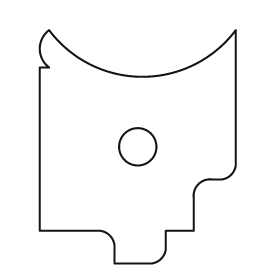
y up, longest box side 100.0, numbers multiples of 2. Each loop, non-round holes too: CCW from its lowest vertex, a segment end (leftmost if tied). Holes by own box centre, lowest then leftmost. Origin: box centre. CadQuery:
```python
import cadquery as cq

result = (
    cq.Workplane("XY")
    .moveTo(-10.0, -50.0)
    .lineTo(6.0, -50.0)
    .threePointArc((10.0, -48.0), (12.0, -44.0))
    .lineTo(12.0, -36.0)
    .lineTo(24.0, -36.0)
    .lineTo(24.0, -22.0)
    .threePointArc((26.0, -16.0), (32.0, -14.0))
    .lineTo(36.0, -14.0)
    .threePointArc((40.0, -12.0), (42.0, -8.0))
    .lineTo(42.0, 50.0)
    .threePointArc((2.0, 30.0), (-38.0, 50.0))
    .threePointArc((-42.0, 42.0), (-38.0, 34.0))
    .lineTo(-42.0, 34.0)
    .lineTo(-42.0, -36.0)
    .lineTo(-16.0, -36.0)
    .threePointArc((-12.0, -38.0), (-10.0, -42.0))
    .close()
    .moveTo(0.0, 0.0)
    .circle(8.0)
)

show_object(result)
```